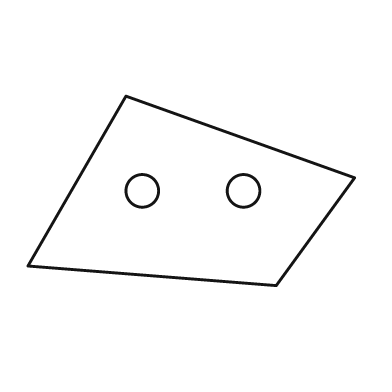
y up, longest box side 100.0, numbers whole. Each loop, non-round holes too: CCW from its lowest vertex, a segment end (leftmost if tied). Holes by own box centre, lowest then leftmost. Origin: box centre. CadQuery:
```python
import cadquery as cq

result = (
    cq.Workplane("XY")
    .moveTo(26.0, -29.0)
    .lineTo(50.0, 4.0)
    .lineTo(-20.0, 29.0)
    .lineTo(-50.0, -23.0)
    .close()
    .moveTo(-15.0, 0.0)
    .circle(5.0)
    .moveTo(16.0, 0.0)
    .circle(5.0)
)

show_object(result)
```